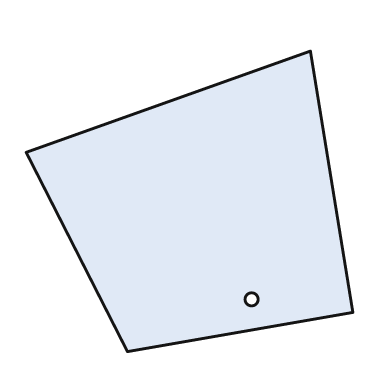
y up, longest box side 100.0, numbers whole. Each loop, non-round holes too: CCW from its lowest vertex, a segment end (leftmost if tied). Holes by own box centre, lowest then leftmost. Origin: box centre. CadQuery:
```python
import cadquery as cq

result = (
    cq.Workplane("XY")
    .moveTo(-19.0, -46.0)
    .lineTo(50.0, -34.0)
    .lineTo(37.0, 46.0)
    .lineTo(-50.0, 15.0)
    .close()
    .moveTo(19.0, -30.0)
    .circle(2.0)
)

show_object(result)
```